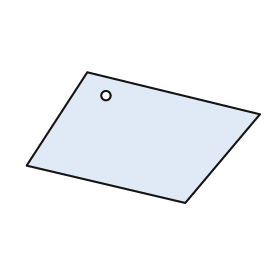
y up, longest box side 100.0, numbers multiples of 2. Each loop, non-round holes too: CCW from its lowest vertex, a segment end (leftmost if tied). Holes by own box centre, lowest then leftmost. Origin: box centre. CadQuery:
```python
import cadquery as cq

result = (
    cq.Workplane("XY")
    .moveTo(18.0, -28.0)
    .lineTo(50.0, 10.0)
    .lineTo(-24.0, 28.0)
    .lineTo(-50.0, -12.0)
    .close()
    .moveTo(-16.0, 18.0)
    .circle(2.0)
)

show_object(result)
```